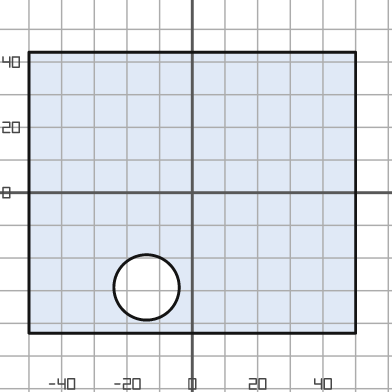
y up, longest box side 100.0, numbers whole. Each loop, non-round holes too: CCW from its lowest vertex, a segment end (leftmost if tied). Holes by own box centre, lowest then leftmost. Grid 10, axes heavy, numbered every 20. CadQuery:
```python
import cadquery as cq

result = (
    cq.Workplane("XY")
    .moveTo(-50.0, -43.0)
    .lineTo(50.0, -43.0)
    .lineTo(50.0, 43.0)
    .lineTo(-50.0, 43.0)
    .close()
    .moveTo(-14.0, -29.0)
    .circle(10.0)
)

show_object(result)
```